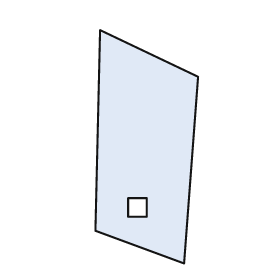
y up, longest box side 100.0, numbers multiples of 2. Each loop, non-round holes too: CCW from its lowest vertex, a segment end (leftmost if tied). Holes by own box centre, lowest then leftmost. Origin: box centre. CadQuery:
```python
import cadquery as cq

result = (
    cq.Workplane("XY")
    .moveTo(16.0, -50.0)
    .lineTo(22.0, 30.0)
    .lineTo(-20.0, 50.0)
    .lineTo(-22.0, -36.0)
    .close()
    .moveTo(-8.0, -30.0)
    .lineTo(0.0, -30.0)
    .lineTo(0.0, -22.0)
    .lineTo(-8.0, -22.0)
    .close()
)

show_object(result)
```